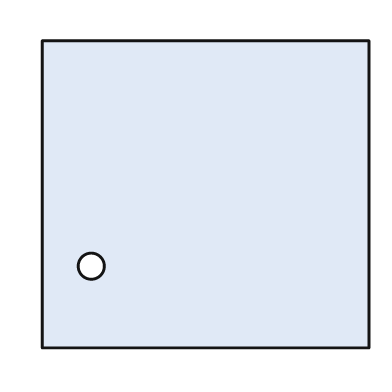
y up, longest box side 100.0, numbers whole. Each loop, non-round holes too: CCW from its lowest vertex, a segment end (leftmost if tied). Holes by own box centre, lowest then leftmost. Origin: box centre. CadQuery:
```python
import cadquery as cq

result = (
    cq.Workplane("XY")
    .moveTo(-50.0, -47.0)
    .lineTo(50.0, -47.0)
    .lineTo(50.0, 47.0)
    .lineTo(-50.0, 47.0)
    .close()
    .moveTo(-35.0, -22.0)
    .circle(4.0)
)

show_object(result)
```